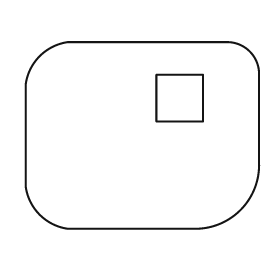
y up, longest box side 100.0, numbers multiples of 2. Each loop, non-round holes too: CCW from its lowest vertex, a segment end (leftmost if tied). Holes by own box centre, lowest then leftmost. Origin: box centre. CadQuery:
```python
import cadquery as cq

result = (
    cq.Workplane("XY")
    .moveTo(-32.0, -40.0)
    .lineTo(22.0, -40.0)
    .threePointArc((42.0, -32.0), (50.0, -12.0))
    .lineTo(50.0, 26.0)
    .threePointArc((46.0, 36.0), (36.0, 40.0))
    .lineTo(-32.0, 40.0)
    .threePointArc((-44.0, 34.0), (-50.0, 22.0))
    .lineTo(-50.0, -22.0)
    .threePointArc((-44.0, -34.0), (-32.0, -40.0))
    .close()
    .moveTo(6.0, 6.0)
    .lineTo(26.0, 6.0)
    .lineTo(26.0, 26.0)
    .lineTo(6.0, 26.0)
    .close()
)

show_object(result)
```